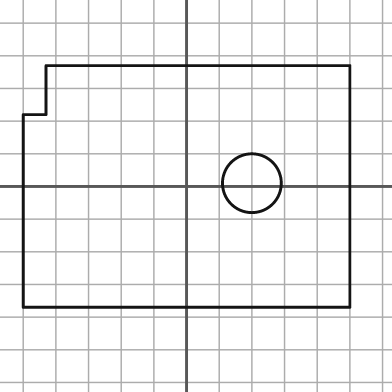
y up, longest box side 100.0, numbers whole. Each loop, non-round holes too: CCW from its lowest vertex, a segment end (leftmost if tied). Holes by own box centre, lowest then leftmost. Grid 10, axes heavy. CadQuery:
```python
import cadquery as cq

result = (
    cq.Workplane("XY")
    .moveTo(-50.0, -37.0)
    .lineTo(50.0, -37.0)
    .lineTo(50.0, 37.0)
    .lineTo(-43.0, 37.0)
    .lineTo(-43.0, 22.0)
    .lineTo(-50.0, 22.0)
    .close()
    .moveTo(20.0, 1.0)
    .circle(9.0)
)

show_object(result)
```